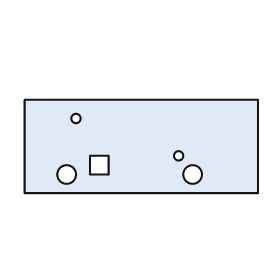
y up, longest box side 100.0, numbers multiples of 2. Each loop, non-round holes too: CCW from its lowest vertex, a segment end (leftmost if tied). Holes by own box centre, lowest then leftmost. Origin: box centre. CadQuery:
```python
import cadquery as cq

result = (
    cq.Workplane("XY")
    .moveTo(-50.0, -20.0)
    .lineTo(50.0, -20.0)
    .lineTo(50.0, 20.0)
    .lineTo(-50.0, 20.0)
    .close()
    .moveTo(-32.0, -12.0)
    .circle(4.0)
    .moveTo(22.0, -12.0)
    .circle(4.0)
    .moveTo(-22.0, -12.0)
    .lineTo(-14.0, -12.0)
    .lineTo(-14.0, -4.0)
    .lineTo(-22.0, -4.0)
    .close()
    .moveTo(16.0, -4.0)
    .circle(2.0)
    .moveTo(-28.0, 12.0)
    .circle(2.0)
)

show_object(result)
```